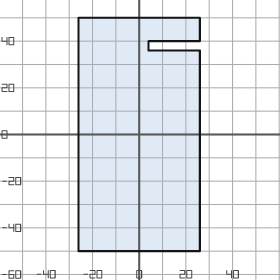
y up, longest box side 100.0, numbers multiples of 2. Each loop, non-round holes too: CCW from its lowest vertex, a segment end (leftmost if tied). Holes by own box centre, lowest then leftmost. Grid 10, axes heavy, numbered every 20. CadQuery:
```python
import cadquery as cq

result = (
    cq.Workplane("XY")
    .moveTo(-26.0, -50.0)
    .lineTo(26.0, -50.0)
    .lineTo(26.0, 36.0)
    .lineTo(4.0, 36.0)
    .lineTo(4.0, 40.0)
    .lineTo(26.0, 40.0)
    .lineTo(26.0, 50.0)
    .lineTo(-26.0, 50.0)
    .close()
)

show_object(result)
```